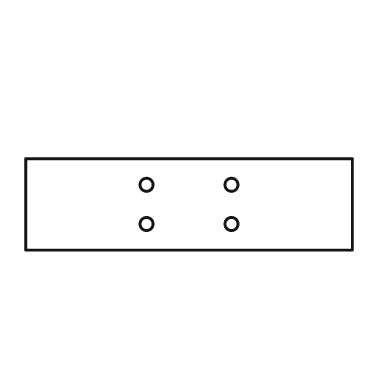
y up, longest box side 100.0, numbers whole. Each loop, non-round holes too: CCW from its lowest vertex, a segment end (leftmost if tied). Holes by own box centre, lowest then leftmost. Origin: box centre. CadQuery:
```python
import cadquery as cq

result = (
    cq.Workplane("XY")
    .moveTo(-50.0, -14.0)
    .lineTo(50.0, -14.0)
    .lineTo(50.0, 14.0)
    .lineTo(-50.0, 14.0)
    .close()
    .moveTo(-13.0, -6.0)
    .circle(2.0)
    .moveTo(13.0, -6.0)
    .circle(2.0)
    .moveTo(-13.0, 6.0)
    .circle(2.0)
    .moveTo(13.0, 6.0)
    .circle(2.0)
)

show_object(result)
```